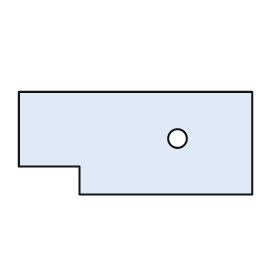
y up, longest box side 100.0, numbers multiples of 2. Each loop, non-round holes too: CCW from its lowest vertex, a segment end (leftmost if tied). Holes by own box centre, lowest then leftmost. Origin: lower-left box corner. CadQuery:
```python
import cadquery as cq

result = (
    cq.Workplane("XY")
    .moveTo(26.0, 0.0)
    .lineTo(100.0, 0.0)
    .lineTo(100.0, 44.0)
    .lineTo(0.0, 44.0)
    .lineTo(0.0, 12.0)
    .lineTo(26.0, 12.0)
    .close()
    .moveTo(68.0, 24.0)
    .circle(4.0)
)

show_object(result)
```